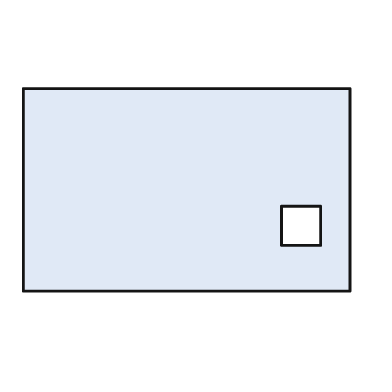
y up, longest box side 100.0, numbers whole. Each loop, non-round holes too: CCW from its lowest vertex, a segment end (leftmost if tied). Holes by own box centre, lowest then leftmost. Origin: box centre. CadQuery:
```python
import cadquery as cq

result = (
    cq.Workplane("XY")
    .moveTo(-50.0, -31.0)
    .lineTo(50.0, -31.0)
    .lineTo(50.0, 31.0)
    .lineTo(-50.0, 31.0)
    .close()
    .moveTo(29.0, -17.0)
    .lineTo(41.0, -17.0)
    .lineTo(41.0, -5.0)
    .lineTo(29.0, -5.0)
    .close()
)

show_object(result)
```